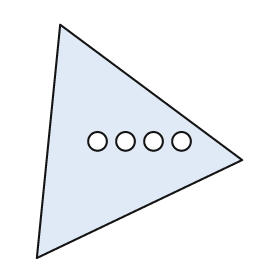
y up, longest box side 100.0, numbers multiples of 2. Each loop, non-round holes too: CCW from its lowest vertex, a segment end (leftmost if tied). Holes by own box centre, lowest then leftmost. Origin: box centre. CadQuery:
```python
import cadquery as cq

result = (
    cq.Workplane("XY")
    .moveTo(-44.0, -50.0)
    .lineTo(44.0, -8.0)
    .lineTo(-34.0, 50.0)
    .close()
    .moveTo(-18.0, 0.0)
    .circle(4.0)
    .moveTo(-6.0, 0.0)
    .circle(4.0)
    .moveTo(6.0, 0.0)
    .circle(4.0)
    .moveTo(18.0, 0.0)
    .circle(4.0)
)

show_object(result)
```